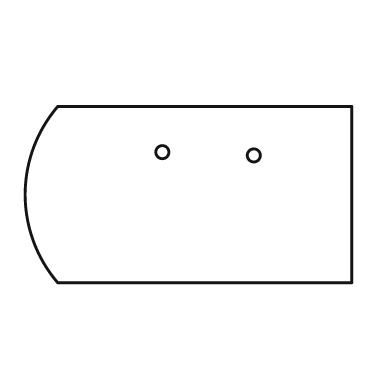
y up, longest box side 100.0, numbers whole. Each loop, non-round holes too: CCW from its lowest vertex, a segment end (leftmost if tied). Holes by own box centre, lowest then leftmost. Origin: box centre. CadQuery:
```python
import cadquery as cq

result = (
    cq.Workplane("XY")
    .moveTo(-40.0, -27.0)
    .lineTo(50.0, -27.0)
    .lineTo(50.0, 27.0)
    .lineTo(-40.0, 27.0)
    .threePointArc((-50.0, 0.0), (-40.0, -27.0))
    .close()
    .moveTo(20.0, 12.0)
    .circle(2.0)
    .moveTo(-8.0, 13.0)
    .circle(2.0)
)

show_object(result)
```